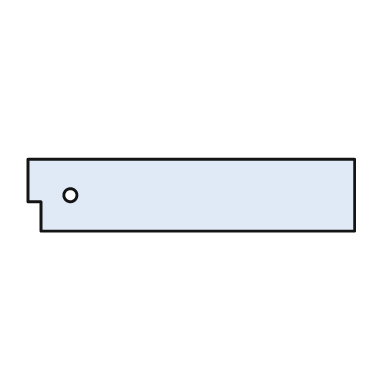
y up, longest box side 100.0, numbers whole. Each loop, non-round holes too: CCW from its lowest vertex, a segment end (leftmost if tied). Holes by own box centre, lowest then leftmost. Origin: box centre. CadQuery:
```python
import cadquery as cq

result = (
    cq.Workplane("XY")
    .moveTo(-46.0, -11.0)
    .lineTo(50.0, -11.0)
    .lineTo(50.0, 11.0)
    .lineTo(-50.0, 11.0)
    .lineTo(-50.0, -2.0)
    .lineTo(-46.0, -2.0)
    .close()
    .moveTo(-37.0, 0.0)
    .circle(2.0)
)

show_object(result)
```